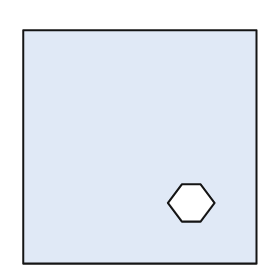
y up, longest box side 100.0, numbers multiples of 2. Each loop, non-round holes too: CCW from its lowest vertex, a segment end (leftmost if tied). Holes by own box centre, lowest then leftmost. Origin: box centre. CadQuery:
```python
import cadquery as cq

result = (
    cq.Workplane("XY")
    .moveTo(-50.0, -50.0)
    .lineTo(50.0, -50.0)
    .lineTo(50.0, 50.0)
    .lineTo(-50.0, 50.0)
    .close()
    .moveTo(18.0, -32.0)
    .lineTo(26.0, -32.0)
    .lineTo(32.0, -24.0)
    .lineTo(26.0, -16.0)
    .lineTo(18.0, -16.0)
    .lineTo(12.0, -24.0)
    .close()
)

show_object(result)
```